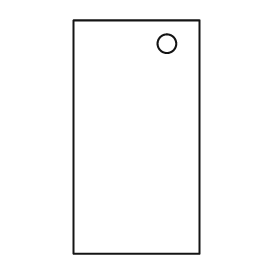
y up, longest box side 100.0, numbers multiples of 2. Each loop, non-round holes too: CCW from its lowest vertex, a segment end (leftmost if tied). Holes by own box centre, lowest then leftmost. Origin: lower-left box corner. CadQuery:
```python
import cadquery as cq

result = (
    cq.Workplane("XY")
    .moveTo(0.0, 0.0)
    .lineTo(54.0, 0.0)
    .lineTo(54.0, 100.0)
    .lineTo(0.0, 100.0)
    .close()
    .moveTo(40.0, 90.0)
    .circle(4.0)
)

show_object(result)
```